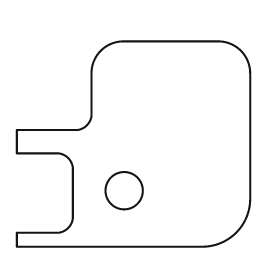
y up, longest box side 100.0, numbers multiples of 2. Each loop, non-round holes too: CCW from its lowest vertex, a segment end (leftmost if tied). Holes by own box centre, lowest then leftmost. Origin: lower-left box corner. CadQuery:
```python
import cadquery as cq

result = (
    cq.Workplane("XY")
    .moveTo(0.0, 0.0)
    .lineTo(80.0, 0.0)
    .threePointArc((94.0, 6.0), (100.0, 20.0))
    .lineTo(100.0, 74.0)
    .threePointArc((96.0, 84.0), (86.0, 88.0))
    .lineTo(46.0, 88.0)
    .threePointArc((36.0, 84.0), (32.0, 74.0))
    .lineTo(32.0, 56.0)
    .threePointArc((30.0, 52.0), (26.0, 50.0))
    .lineTo(0.0, 50.0)
    .lineTo(0.0, 40.0)
    .lineTo(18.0, 40.0)
    .threePointArc((22.0, 38.0), (24.0, 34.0))
    .lineTo(24.0, 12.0)
    .threePointArc((22.0, 8.0), (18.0, 6.0))
    .lineTo(0.0, 6.0)
    .close()
    .moveTo(46.0, 24.0)
    .circle(8.0)
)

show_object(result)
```